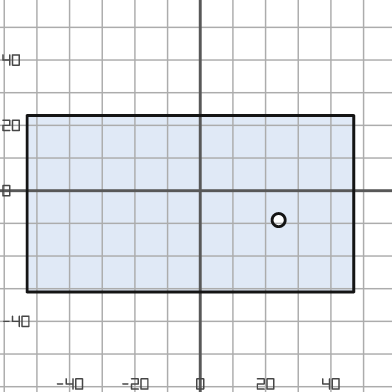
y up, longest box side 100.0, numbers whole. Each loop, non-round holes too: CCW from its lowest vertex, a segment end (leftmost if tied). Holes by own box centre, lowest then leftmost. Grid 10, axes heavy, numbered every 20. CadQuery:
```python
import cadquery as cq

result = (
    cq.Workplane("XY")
    .moveTo(-53.0, -31.0)
    .lineTo(47.0, -31.0)
    .lineTo(47.0, 23.0)
    .lineTo(-53.0, 23.0)
    .close()
    .moveTo(24.0, -9.0)
    .circle(2.0)
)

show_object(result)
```